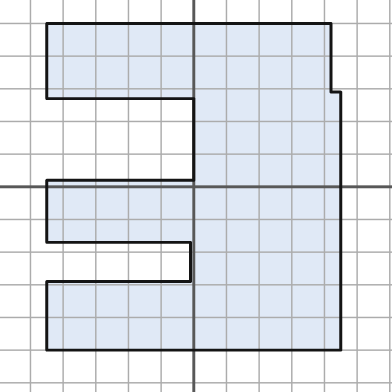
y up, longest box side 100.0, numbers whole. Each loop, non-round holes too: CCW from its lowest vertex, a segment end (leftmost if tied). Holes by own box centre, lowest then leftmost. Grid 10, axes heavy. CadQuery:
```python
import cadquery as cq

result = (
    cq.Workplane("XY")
    .moveTo(-45.0, -50.0)
    .lineTo(45.0, -50.0)
    .lineTo(45.0, 29.0)
    .lineTo(42.0, 29.0)
    .lineTo(42.0, 50.0)
    .lineTo(-45.0, 50.0)
    .lineTo(-45.0, 27.0)
    .lineTo(0.0, 27.0)
    .lineTo(0.0, 2.0)
    .lineTo(-45.0, 2.0)
    .lineTo(-45.0, -17.0)
    .lineTo(-1.0, -17.0)
    .lineTo(-1.0, -29.0)
    .lineTo(-45.0, -29.0)
    .close()
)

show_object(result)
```